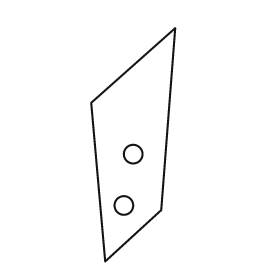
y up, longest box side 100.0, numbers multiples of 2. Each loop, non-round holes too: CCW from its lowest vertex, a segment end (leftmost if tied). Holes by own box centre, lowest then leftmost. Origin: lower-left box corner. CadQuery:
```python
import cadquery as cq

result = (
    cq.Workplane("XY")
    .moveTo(6.0, 0.0)
    .lineTo(30.0, 22.0)
    .lineTo(36.0, 100.0)
    .lineTo(0.0, 68.0)
    .close()
    .moveTo(14.0, 24.0)
    .circle(4.0)
    .moveTo(18.0, 46.0)
    .circle(4.0)
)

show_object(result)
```